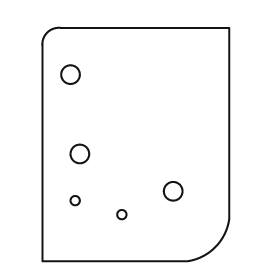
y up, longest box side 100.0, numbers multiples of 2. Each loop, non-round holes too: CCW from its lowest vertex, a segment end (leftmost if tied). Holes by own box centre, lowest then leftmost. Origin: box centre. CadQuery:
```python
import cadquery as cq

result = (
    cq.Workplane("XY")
    .moveTo(-40.0, -50.0)
    .lineTo(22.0, -50.0)
    .threePointArc((34.0, -44.0), (40.0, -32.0))
    .lineTo(40.0, 50.0)
    .lineTo(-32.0, 50.0)
    .threePointArc((-38.0, 48.0), (-40.0, 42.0))
    .close()
    .moveTo(-6.0, -30.0)
    .circle(2.0)
    .moveTo(-26.0, -24.0)
    .circle(2.0)
    .moveTo(16.0, -20.0)
    .circle(4.0)
    .moveTo(-24.0, -4.0)
    .circle(4.0)
    .moveTo(-28.0, 30.0)
    .circle(4.0)
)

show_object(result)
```